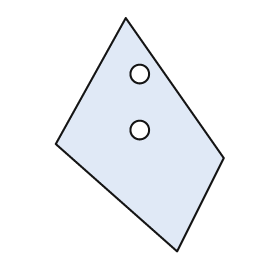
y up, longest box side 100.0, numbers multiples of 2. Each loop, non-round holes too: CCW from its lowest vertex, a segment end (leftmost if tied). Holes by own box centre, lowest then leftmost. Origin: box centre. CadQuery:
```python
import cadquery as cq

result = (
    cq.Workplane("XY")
    .moveTo(16.0, -50.0)
    .lineTo(36.0, -10.0)
    .lineTo(-6.0, 50.0)
    .lineTo(-36.0, -4.0)
    .close()
    .moveTo(0.0, 2.0)
    .circle(4.0)
    .moveTo(0.0, 26.0)
    .circle(4.0)
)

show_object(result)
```